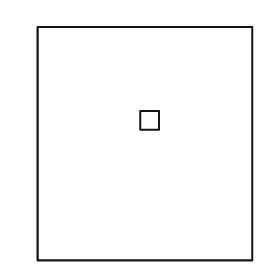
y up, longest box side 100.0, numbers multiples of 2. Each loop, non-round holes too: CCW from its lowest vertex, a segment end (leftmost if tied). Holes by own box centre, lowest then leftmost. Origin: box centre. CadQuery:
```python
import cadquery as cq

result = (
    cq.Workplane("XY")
    .moveTo(-46.0, -50.0)
    .lineTo(46.0, -50.0)
    .lineTo(46.0, 50.0)
    .lineTo(-46.0, 50.0)
    .close()
    .moveTo(-2.0, 6.0)
    .lineTo(6.0, 6.0)
    .lineTo(6.0, 14.0)
    .lineTo(-2.0, 14.0)
    .close()
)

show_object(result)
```